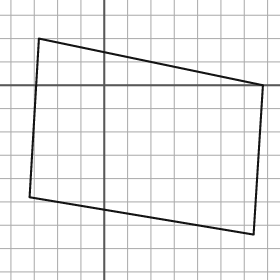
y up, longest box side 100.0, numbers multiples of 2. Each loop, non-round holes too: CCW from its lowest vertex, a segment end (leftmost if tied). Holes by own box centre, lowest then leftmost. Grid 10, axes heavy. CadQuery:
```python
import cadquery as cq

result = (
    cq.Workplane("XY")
    .moveTo(64.0, -64.0)
    .lineTo(68.0, 0.0)
    .lineTo(-28.0, 20.0)
    .lineTo(-32.0, -48.0)
    .close()
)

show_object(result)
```